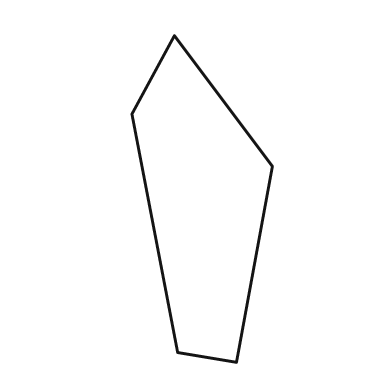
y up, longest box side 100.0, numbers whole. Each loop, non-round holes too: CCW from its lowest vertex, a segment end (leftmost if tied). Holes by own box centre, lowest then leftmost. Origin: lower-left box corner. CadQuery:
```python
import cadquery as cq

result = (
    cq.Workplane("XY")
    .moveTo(32.0, 0.0)
    .lineTo(43.0, 60.0)
    .lineTo(13.0, 100.0)
    .lineTo(0.0, 76.0)
    .lineTo(14.0, 3.0)
    .close()
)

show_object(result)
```